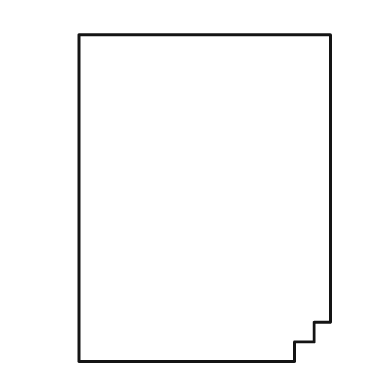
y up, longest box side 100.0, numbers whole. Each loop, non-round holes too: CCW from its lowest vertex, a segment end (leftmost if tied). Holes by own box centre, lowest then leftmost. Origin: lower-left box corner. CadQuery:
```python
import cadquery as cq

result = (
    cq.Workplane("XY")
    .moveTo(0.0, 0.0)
    .lineTo(66.0, 0.0)
    .lineTo(66.0, 6.0)
    .lineTo(72.0, 6.0)
    .lineTo(72.0, 12.0)
    .lineTo(77.0, 12.0)
    .lineTo(77.0, 100.0)
    .lineTo(0.0, 100.0)
    .close()
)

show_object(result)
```